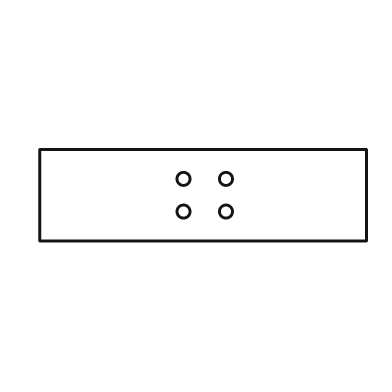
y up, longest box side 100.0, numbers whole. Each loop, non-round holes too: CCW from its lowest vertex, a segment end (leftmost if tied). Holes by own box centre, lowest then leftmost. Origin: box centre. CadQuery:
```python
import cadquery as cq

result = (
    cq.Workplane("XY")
    .moveTo(-50.0, -14.0)
    .lineTo(50.0, -14.0)
    .lineTo(50.0, 14.0)
    .lineTo(-50.0, 14.0)
    .close()
    .moveTo(-6.0, -5.0)
    .circle(2.0)
    .moveTo(7.0, -5.0)
    .circle(2.0)
    .moveTo(-6.0, 5.0)
    .circle(2.0)
    .moveTo(7.0, 5.0)
    .circle(2.0)
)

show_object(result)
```